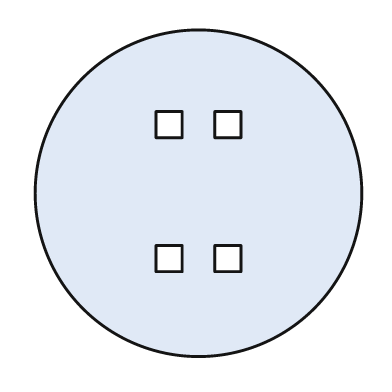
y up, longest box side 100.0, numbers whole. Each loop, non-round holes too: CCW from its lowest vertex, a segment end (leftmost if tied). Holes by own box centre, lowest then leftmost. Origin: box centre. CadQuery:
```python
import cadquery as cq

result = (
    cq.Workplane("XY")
    .moveTo(0.0, 0.0)
    .circle(50.0)
    .moveTo(-13.0, -24.0)
    .lineTo(-5.0, -24.0)
    .lineTo(-5.0, -16.0)
    .lineTo(-13.0, -16.0)
    .close()
    .moveTo(5.0, -24.0)
    .lineTo(13.0, -24.0)
    .lineTo(13.0, -16.0)
    .lineTo(5.0, -16.0)
    .close()
    .moveTo(-13.0, 17.0)
    .lineTo(-5.0, 17.0)
    .lineTo(-5.0, 25.0)
    .lineTo(-13.0, 25.0)
    .close()
    .moveTo(5.0, 17.0)
    .lineTo(13.0, 17.0)
    .lineTo(13.0, 25.0)
    .lineTo(5.0, 25.0)
    .close()
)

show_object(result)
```